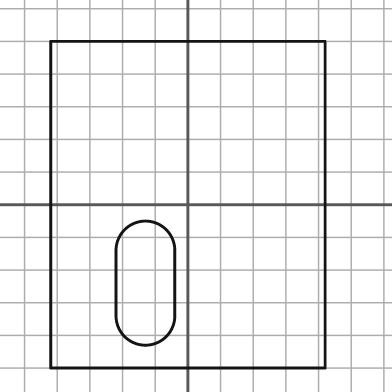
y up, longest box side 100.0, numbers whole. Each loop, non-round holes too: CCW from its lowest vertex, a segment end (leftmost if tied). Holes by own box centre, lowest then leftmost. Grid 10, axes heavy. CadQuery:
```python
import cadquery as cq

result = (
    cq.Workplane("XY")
    .moveTo(-42.0, -50.0)
    .lineTo(42.0, -50.0)
    .lineTo(42.0, 50.0)
    .lineTo(-42.0, 50.0)
    .close()
    .moveTo(-22.0, -34.0)
    .threePointArc((-13.0, -43.0), (-4.0, -34.0))
    .lineTo(-4.0, -14.0)
    .threePointArc((-13.0, -5.0), (-22.0, -14.0))
    .close()
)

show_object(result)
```